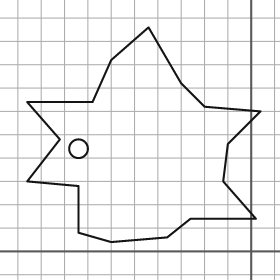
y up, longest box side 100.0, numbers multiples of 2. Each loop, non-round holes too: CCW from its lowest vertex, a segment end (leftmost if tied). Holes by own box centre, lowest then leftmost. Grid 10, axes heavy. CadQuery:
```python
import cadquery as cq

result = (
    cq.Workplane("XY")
    .moveTo(-60.0, 4.0)
    .lineTo(-36.0, 6.0)
    .lineTo(-26.0, 14.0)
    .lineTo(2.0, 14.0)
    .lineTo(-12.0, 30.0)
    .lineTo(-10.0, 46.0)
    .lineTo(4.0, 60.0)
    .lineTo(-20.0, 62.0)
    .lineTo(-30.0, 72.0)
    .lineTo(-44.0, 96.0)
    .lineTo(-60.0, 82.0)
    .lineTo(-68.0, 64.0)
    .lineTo(-96.0, 64.0)
    .lineTo(-82.0, 48.0)
    .lineTo(-96.0, 30.0)
    .lineTo(-74.0, 28.0)
    .lineTo(-74.0, 8.0)
    .close()
    .moveTo(-74.0, 44.0)
    .circle(4.0)
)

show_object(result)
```